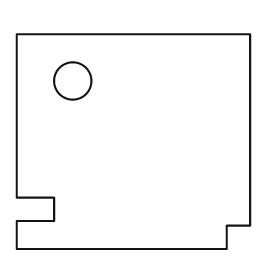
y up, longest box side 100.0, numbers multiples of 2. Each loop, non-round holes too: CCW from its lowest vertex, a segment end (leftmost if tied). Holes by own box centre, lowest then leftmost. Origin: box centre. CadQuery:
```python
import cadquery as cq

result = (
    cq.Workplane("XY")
    .moveTo(-50.0, -46.0)
    .lineTo(40.0, -46.0)
    .lineTo(40.0, -36.0)
    .lineTo(50.0, -36.0)
    .lineTo(50.0, 46.0)
    .lineTo(-50.0, 46.0)
    .lineTo(-50.0, -24.0)
    .lineTo(-34.0, -24.0)
    .lineTo(-34.0, -34.0)
    .lineTo(-50.0, -34.0)
    .close()
    .moveTo(-26.0, 26.0)
    .circle(8.0)
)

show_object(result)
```